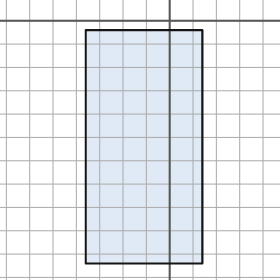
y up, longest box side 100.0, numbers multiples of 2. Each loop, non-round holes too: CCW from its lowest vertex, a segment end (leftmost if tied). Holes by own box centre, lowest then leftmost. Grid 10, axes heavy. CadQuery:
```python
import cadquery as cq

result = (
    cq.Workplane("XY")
    .moveTo(-36.0, -104.0)
    .lineTo(14.0, -104.0)
    .lineTo(14.0, -4.0)
    .lineTo(-36.0, -4.0)
    .close()
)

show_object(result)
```